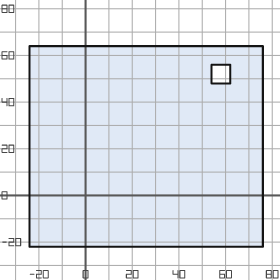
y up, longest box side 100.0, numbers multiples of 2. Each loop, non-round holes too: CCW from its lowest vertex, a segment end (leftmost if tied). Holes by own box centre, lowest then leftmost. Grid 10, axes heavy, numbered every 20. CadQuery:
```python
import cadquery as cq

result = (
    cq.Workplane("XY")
    .moveTo(-24.0, -22.0)
    .lineTo(76.0, -22.0)
    .lineTo(76.0, 64.0)
    .lineTo(-24.0, 64.0)
    .close()
    .moveTo(54.0, 48.0)
    .lineTo(62.0, 48.0)
    .lineTo(62.0, 56.0)
    .lineTo(54.0, 56.0)
    .close()
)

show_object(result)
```